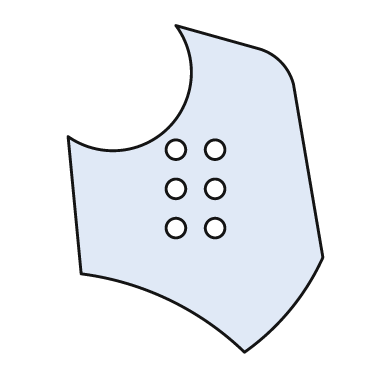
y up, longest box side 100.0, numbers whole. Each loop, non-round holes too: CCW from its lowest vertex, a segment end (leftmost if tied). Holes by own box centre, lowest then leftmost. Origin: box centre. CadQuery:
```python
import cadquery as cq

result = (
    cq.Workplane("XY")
    .moveTo(15.0, -50.0)
    .threePointArc((29.0, -37.0), (39.0, -21.0))
    .lineTo(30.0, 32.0)
    .threePointArc((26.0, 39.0), (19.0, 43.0))
    .lineTo(-6.0, 50.0)
    .threePointArc((-8.0, 19.0), (-39.0, 16.0))
    .lineTo(-35.0, -26.0)
    .threePointArc((-8.0, -34.0), (15.0, -50.0))
    .close()
    .moveTo(-6.0, -12.0)
    .circle(3.0)
    .moveTo(6.0, -12.0)
    .circle(3.0)
    .moveTo(-6.0, 0.0)
    .circle(3.0)
    .moveTo(6.0, 0.0)
    .circle(3.0)
    .moveTo(-6.0, 12.0)
    .circle(3.0)
    .moveTo(6.0, 12.0)
    .circle(3.0)
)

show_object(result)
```